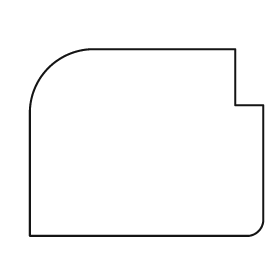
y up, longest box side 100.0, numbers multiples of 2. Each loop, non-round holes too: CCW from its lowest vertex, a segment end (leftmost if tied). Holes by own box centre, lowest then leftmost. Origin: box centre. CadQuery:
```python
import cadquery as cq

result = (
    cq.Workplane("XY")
    .moveTo(-50.0, -40.0)
    .lineTo(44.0, -40.0)
    .threePointArc((48.0, -38.0), (50.0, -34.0))
    .lineTo(50.0, 16.0)
    .lineTo(38.0, 16.0)
    .lineTo(38.0, 40.0)
    .lineTo(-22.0, 40.0)
    .threePointArc((-42.0, 32.0), (-50.0, 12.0))
    .close()
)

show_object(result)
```